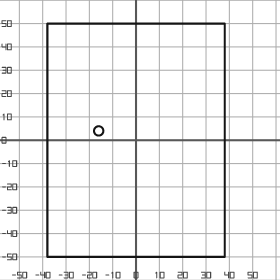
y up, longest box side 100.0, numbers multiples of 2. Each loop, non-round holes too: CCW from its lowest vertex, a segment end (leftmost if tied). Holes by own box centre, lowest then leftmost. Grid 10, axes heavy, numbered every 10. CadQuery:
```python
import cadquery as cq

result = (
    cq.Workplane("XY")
    .moveTo(-38.0, -50.0)
    .lineTo(38.0, -50.0)
    .lineTo(38.0, 50.0)
    .lineTo(-38.0, 50.0)
    .close()
    .moveTo(-16.0, 4.0)
    .circle(2.0)
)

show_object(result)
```